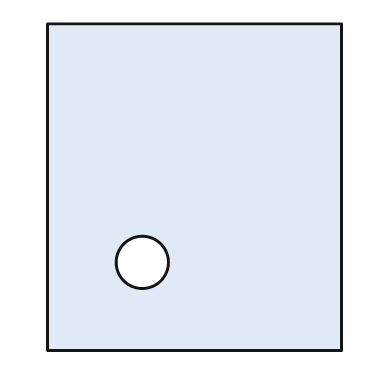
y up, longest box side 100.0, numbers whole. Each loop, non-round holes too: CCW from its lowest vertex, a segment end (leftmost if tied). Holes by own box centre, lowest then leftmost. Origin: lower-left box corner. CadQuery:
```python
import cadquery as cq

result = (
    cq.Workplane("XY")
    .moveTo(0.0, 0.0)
    .lineTo(90.0, 0.0)
    .lineTo(90.0, 100.0)
    .lineTo(0.0, 100.0)
    .close()
    .moveTo(29.0, 27.0)
    .circle(8.0)
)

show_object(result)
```